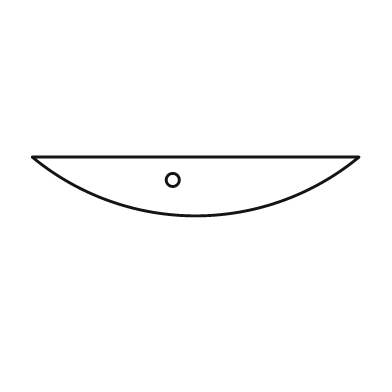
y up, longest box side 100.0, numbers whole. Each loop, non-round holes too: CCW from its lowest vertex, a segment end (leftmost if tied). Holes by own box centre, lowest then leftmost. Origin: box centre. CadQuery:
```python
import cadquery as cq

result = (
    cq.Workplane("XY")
    .moveTo(-50.0, 9.0)
    .threePointArc((0.0, -9.0), (50.0, 9.0))
    .close()
    .moveTo(-7.0, 2.0)
    .circle(2.0)
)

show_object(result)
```